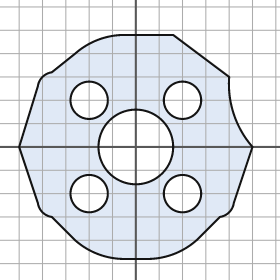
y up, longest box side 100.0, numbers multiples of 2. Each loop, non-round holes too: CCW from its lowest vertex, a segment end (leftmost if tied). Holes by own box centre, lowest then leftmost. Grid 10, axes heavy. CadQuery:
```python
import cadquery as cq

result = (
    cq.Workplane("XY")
    .moveTo(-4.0, -48.0)
    .lineTo(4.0, -48.0)
    .threePointArc((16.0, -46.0), (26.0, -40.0))
    .lineTo(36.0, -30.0)
    .threePointArc((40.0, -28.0), (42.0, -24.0))
    .lineTo(50.0, 0.0)
    .threePointArc((42.0, 14.0), (40.0, 30.0))
    .lineTo(16.0, 48.0)
    .lineTo(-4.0, 48.0)
    .threePointArc((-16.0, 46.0), (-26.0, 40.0))
    .lineTo(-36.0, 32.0)
    .threePointArc((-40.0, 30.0), (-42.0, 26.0))
    .lineTo(-50.0, 0.0)
    .lineTo(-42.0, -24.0)
    .threePointArc((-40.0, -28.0), (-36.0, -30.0))
    .lineTo(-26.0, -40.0)
    .threePointArc((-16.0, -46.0), (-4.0, -48.0))
    .close()
    .moveTo(-20.0, -20.0)
    .circle(8.0)
    .moveTo(20.0, -20.0)
    .circle(8.0)
    .moveTo(0.0, 0.0)
    .circle(16.0)
    .moveTo(-20.0, 20.0)
    .circle(8.0)
    .moveTo(20.0, 20.0)
    .circle(8.0)
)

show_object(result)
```